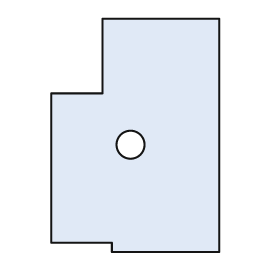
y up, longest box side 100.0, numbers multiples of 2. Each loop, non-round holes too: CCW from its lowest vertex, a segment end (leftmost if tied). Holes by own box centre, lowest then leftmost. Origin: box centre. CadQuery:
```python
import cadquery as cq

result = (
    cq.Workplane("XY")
    .moveTo(-10.0, -50.0)
    .lineTo(36.0, -50.0)
    .lineTo(36.0, 50.0)
    .lineTo(-14.0, 50.0)
    .lineTo(-14.0, 18.0)
    .lineTo(-36.0, 18.0)
    .lineTo(-36.0, -46.0)
    .lineTo(-10.0, -46.0)
    .close()
    .moveTo(-2.0, -4.0)
    .circle(6.0)
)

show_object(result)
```